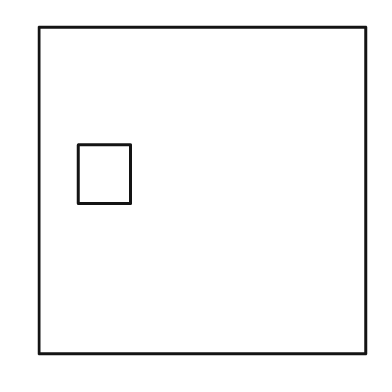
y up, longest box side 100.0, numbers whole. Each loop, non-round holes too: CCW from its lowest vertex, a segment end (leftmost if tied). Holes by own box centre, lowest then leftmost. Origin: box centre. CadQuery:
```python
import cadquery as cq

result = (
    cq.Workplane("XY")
    .moveTo(-50.0, -50.0)
    .lineTo(50.0, -50.0)
    .lineTo(50.0, 50.0)
    .lineTo(-50.0, 50.0)
    .close()
    .moveTo(-38.0, -4.0)
    .lineTo(-22.0, -4.0)
    .lineTo(-22.0, 14.0)
    .lineTo(-38.0, 14.0)
    .close()
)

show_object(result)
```